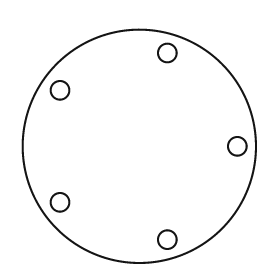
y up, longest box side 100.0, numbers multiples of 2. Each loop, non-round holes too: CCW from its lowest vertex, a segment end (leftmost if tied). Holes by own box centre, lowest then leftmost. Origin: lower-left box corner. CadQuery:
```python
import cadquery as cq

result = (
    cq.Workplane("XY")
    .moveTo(50.0, 50.0)
    .circle(50.0)
    .moveTo(62.0, 10.0)
    .circle(4.0)
    .moveTo(16.0, 26.0)
    .circle(4.0)
    .moveTo(92.0, 50.0)
    .circle(4.0)
    .moveTo(16.0, 74.0)
    .circle(4.0)
    .moveTo(62.0, 90.0)
    .circle(4.0)
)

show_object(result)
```